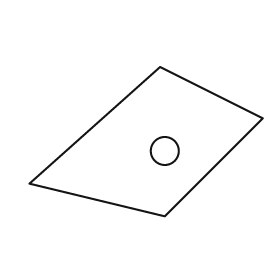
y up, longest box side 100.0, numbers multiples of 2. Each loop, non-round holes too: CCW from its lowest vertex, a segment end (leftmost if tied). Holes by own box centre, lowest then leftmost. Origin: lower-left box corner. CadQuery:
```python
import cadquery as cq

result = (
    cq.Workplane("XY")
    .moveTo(58.0, 0.0)
    .lineTo(100.0, 42.0)
    .lineTo(56.0, 64.0)
    .lineTo(0.0, 14.0)
    .close()
    .moveTo(58.0, 28.0)
    .circle(6.0)
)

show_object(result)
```